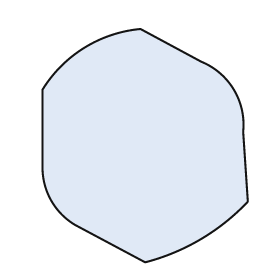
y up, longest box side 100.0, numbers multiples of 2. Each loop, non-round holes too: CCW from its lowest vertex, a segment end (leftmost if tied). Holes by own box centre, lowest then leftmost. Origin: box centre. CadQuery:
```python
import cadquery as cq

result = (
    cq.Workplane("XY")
    .moveTo(0.0, -50.0)
    .threePointArc((24.0, -40.0), (44.0, -24.0))
    .lineTo(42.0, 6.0)
    .threePointArc((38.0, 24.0), (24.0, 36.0))
    .lineTo(-2.0, 50.0)
    .threePointArc((-26.0, 42.0), (-44.0, 24.0))
    .lineTo(-44.0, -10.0)
    .threePointArc((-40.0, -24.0), (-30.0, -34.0))
    .close()
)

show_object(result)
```